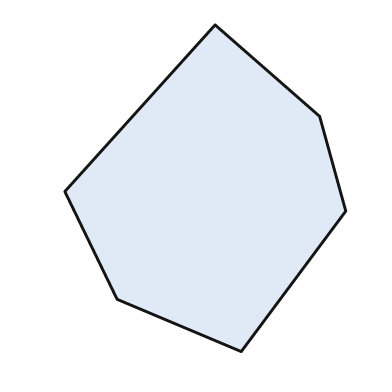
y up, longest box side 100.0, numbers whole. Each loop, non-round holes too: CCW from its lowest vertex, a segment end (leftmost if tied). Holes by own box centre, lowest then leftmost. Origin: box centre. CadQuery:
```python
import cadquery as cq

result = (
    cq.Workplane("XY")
    .moveTo(11.0, -50.0)
    .lineTo(43.0, -7.0)
    .lineTo(35.0, 22.0)
    .lineTo(3.0, 50.0)
    .lineTo(-43.0, -1.0)
    .lineTo(-27.0, -34.0)
    .close()
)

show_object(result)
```